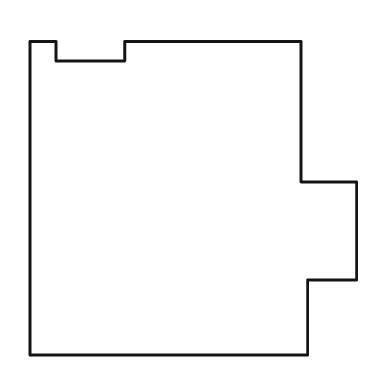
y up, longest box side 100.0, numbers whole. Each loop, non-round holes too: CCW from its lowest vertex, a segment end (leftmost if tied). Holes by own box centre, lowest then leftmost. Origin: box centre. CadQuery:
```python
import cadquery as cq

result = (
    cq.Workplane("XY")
    .moveTo(-50.0, -48.0)
    .lineTo(35.0, -48.0)
    .lineTo(35.0, -25.0)
    .lineTo(50.0, -25.0)
    .lineTo(50.0, 5.0)
    .lineTo(33.0, 5.0)
    .lineTo(33.0, 48.0)
    .lineTo(-21.0, 48.0)
    .lineTo(-21.0, 42.0)
    .lineTo(-42.0, 42.0)
    .lineTo(-42.0, 48.0)
    .lineTo(-50.0, 48.0)
    .close()
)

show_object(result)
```